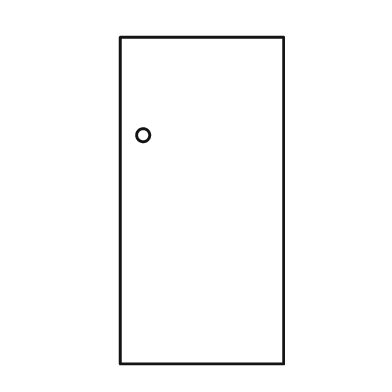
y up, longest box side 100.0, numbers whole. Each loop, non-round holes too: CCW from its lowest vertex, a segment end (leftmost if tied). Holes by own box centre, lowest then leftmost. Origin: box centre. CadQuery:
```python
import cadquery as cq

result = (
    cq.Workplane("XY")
    .moveTo(-25.0, -50.0)
    .lineTo(25.0, -50.0)
    .lineTo(25.0, 50.0)
    .lineTo(-25.0, 50.0)
    .close()
    .moveTo(-18.0, 20.0)
    .circle(2.0)
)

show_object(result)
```